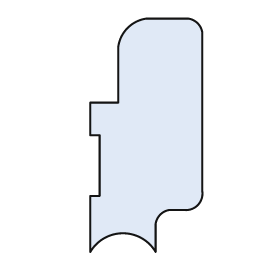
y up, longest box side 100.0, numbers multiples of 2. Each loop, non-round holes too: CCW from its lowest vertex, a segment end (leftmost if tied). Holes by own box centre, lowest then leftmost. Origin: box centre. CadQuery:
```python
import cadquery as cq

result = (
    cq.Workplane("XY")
    .moveTo(-24.0, -50.0)
    .threePointArc((-10.0, -42.0), (4.0, -50.0))
    .lineTo(4.0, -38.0)
    .threePointArc((6.0, -34.0), (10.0, -32.0))
    .lineTo(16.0, -32.0)
    .threePointArc((22.0, -30.0), (24.0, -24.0))
    .lineTo(24.0, 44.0)
    .threePointArc((22.0, 48.0), (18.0, 50.0))
    .lineTo(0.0, 50.0)
    .threePointArc((-8.0, 46.0), (-12.0, 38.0))
    .lineTo(-12.0, 14.0)
    .lineTo(-24.0, 14.0)
    .lineTo(-24.0, 0.0)
    .lineTo(-20.0, 0.0)
    .lineTo(-20.0, -26.0)
    .lineTo(-24.0, -26.0)
    .close()
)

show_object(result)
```